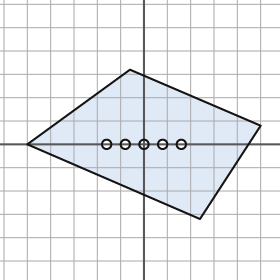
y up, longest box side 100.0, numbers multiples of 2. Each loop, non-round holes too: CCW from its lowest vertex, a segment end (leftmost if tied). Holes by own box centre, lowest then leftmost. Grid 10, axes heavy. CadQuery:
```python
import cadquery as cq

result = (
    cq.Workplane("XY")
    .moveTo(24.0, -32.0)
    .lineTo(50.0, 8.0)
    .lineTo(-6.0, 32.0)
    .lineTo(-50.0, 0.0)
    .close()
    .moveTo(-16.0, 0.0)
    .circle(2.0)
    .moveTo(-8.0, 0.0)
    .circle(2.0)
    .moveTo(0.0, 0.0)
    .circle(2.0)
    .moveTo(8.0, 0.0)
    .circle(2.0)
    .moveTo(16.0, 0.0)
    .circle(2.0)
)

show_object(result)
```